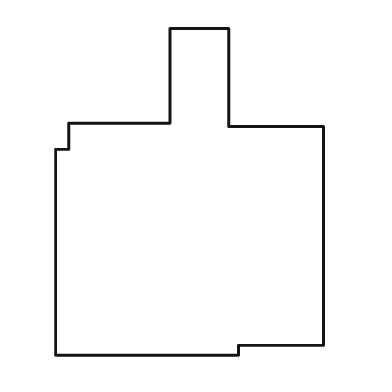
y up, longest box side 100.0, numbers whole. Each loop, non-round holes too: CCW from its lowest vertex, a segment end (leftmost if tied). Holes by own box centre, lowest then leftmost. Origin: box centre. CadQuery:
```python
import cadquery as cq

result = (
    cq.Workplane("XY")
    .moveTo(-41.0, -50.0)
    .lineTo(15.0, -50.0)
    .lineTo(15.0, -47.0)
    .lineTo(41.0, -47.0)
    .lineTo(41.0, 20.0)
    .lineTo(12.0, 20.0)
    .lineTo(12.0, 50.0)
    .lineTo(-6.0, 50.0)
    .lineTo(-6.0, 21.0)
    .lineTo(-37.0, 21.0)
    .lineTo(-37.0, 13.0)
    .lineTo(-41.0, 13.0)
    .close()
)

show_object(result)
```